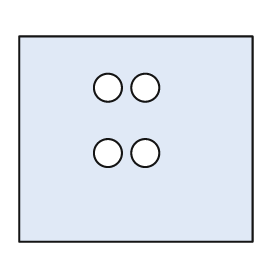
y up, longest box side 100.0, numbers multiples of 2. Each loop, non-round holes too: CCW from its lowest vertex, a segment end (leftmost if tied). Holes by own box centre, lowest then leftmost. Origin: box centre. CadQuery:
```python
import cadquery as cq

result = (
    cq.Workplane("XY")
    .moveTo(-50.0, -44.0)
    .lineTo(50.0, -44.0)
    .lineTo(50.0, 44.0)
    .lineTo(-50.0, 44.0)
    .close()
    .moveTo(-12.0, -6.0)
    .circle(6.0)
    .moveTo(4.0, -6.0)
    .circle(6.0)
    .moveTo(-12.0, 22.0)
    .circle(6.0)
    .moveTo(4.0, 22.0)
    .circle(6.0)
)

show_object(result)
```